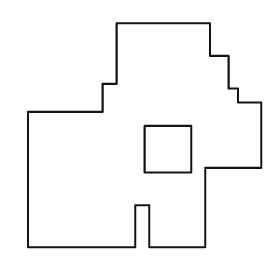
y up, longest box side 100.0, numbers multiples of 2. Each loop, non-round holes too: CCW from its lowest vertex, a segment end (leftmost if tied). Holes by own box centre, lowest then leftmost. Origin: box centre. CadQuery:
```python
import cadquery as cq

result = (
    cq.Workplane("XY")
    .moveTo(-50.0, -48.0)
    .lineTo(-4.0, -48.0)
    .lineTo(-4.0, -30.0)
    .lineTo(2.0, -30.0)
    .lineTo(2.0, -48.0)
    .lineTo(26.0, -48.0)
    .lineTo(26.0, -14.0)
    .lineTo(50.0, -14.0)
    .lineTo(50.0, 14.0)
    .lineTo(40.0, 14.0)
    .lineTo(40.0, 20.0)
    .lineTo(36.0, 20.0)
    .lineTo(36.0, 34.0)
    .lineTo(28.0, 34.0)
    .lineTo(28.0, 48.0)
    .lineTo(-12.0, 48.0)
    .lineTo(-12.0, 22.0)
    .lineTo(-18.0, 22.0)
    .lineTo(-18.0, 10.0)
    .lineTo(-50.0, 10.0)
    .close()
    .moveTo(0.0, -16.0)
    .lineTo(20.0, -16.0)
    .lineTo(20.0, 4.0)
    .lineTo(0.0, 4.0)
    .close()
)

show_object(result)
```